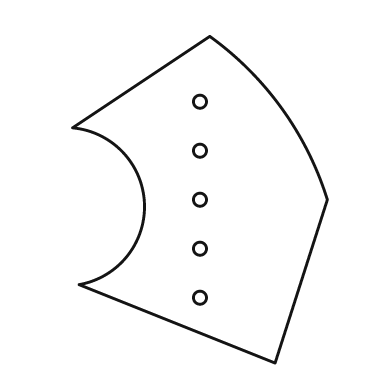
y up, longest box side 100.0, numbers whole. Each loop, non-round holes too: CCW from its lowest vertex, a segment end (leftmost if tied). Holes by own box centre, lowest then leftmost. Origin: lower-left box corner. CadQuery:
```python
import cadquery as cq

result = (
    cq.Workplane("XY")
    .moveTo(62.0, 0.0)
    .lineTo(78.0, 50.0)
    .threePointArc((64.0, 78.0), (42.0, 100.0))
    .lineTo(0.0, 72.0)
    .threePointArc((22.0, 49.0), (2.0, 24.0))
    .close()
    .moveTo(39.0, 20.0)
    .circle(2.0)
    .moveTo(39.0, 35.0)
    .circle(2.0)
    .moveTo(39.0, 50.0)
    .circle(2.0)
    .moveTo(39.0, 65.0)
    .circle(2.0)
    .moveTo(39.0, 80.0)
    .circle(2.0)
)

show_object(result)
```